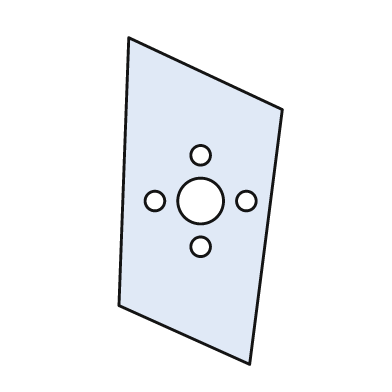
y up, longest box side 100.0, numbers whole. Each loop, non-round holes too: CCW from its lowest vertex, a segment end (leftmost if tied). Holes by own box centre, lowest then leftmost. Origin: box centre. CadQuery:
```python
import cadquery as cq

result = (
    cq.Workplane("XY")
    .moveTo(15.0, -50.0)
    .lineTo(25.0, 28.0)
    .lineTo(-22.0, 50.0)
    .lineTo(-25.0, -32.0)
    .close()
    .moveTo(0.0, -14.0)
    .circle(3.0)
    .moveTo(-14.0, 0.0)
    .circle(3.0)
    .moveTo(0.0, 0.0)
    .circle(7.0)
    .moveTo(14.0, 0.0)
    .circle(3.0)
    .moveTo(0.0, 14.0)
    .circle(3.0)
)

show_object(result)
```